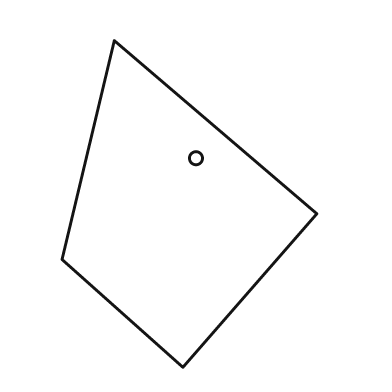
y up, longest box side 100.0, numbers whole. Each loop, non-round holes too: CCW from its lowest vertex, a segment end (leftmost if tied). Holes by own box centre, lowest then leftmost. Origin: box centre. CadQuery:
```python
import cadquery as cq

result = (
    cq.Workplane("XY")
    .moveTo(-2.0, -50.0)
    .lineTo(39.0, -3.0)
    .lineTo(-23.0, 50.0)
    .lineTo(-39.0, -17.0)
    .close()
    .moveTo(2.0, 14.0)
    .circle(2.0)
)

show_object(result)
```